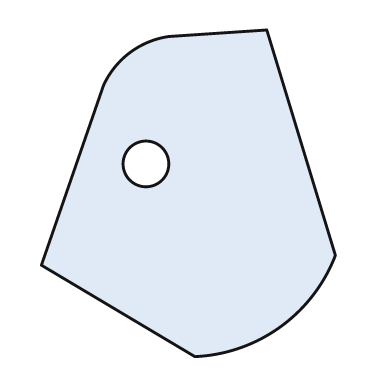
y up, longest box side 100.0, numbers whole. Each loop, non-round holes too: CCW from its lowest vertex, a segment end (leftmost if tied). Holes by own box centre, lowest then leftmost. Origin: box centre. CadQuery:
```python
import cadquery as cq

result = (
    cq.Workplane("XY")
    .moveTo(2.0, -50.0)
    .threePointArc((28.0, -41.0), (45.0, -19.0))
    .lineTo(24.0, 50.0)
    .lineTo(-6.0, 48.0)
    .threePointArc((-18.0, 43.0), (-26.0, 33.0))
    .lineTo(-45.0, -22.0)
    .close()
    .moveTo(-13.0, 9.0)
    .circle(7.0)
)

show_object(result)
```